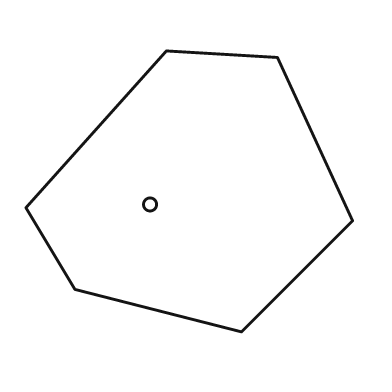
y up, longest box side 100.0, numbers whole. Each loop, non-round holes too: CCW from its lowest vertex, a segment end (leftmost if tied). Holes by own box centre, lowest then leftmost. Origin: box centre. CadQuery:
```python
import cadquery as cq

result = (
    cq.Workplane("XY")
    .moveTo(16.0, -43.0)
    .lineTo(50.0, -9.0)
    .lineTo(27.0, 41.0)
    .lineTo(-7.0, 43.0)
    .lineTo(-50.0, -5.0)
    .lineTo(-35.0, -30.0)
    .close()
    .moveTo(-12.0, -4.0)
    .circle(2.0)
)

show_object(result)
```